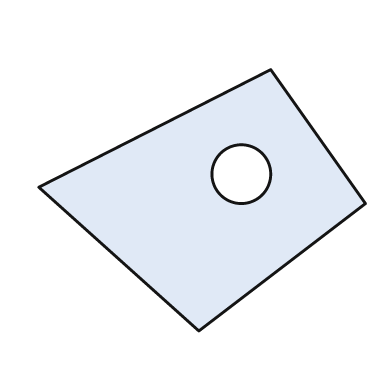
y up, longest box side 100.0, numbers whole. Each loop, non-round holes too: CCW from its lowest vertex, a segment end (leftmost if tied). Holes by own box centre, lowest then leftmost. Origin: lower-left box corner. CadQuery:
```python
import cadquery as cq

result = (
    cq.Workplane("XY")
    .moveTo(49.0, 0.0)
    .lineTo(100.0, 39.0)
    .lineTo(71.0, 80.0)
    .lineTo(0.0, 44.0)
    .close()
    .moveTo(62.0, 48.0)
    .circle(9.0)
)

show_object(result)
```